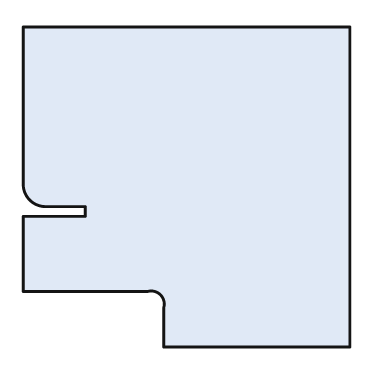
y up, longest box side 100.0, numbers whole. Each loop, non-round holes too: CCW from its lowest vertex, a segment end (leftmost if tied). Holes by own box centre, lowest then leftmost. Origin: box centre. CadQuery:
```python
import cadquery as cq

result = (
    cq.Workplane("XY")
    .moveTo(-7.0, -49.0)
    .lineTo(50.0, -49.0)
    .lineTo(50.0, 49.0)
    .lineTo(-50.0, 49.0)
    .lineTo(-50.0, 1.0)
    .threePointArc((-48.0, -4.0), (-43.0, -6.0))
    .lineTo(-31.0, -6.0)
    .lineTo(-31.0, -9.0)
    .lineTo(-50.0, -9.0)
    .lineTo(-50.0, -32.0)
    .lineTo(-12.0, -32.0)
    .threePointArc((-8.0, -33.0), (-7.0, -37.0))
    .close()
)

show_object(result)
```